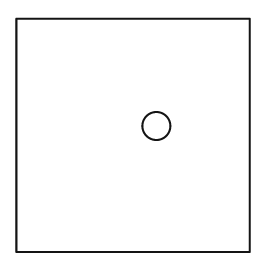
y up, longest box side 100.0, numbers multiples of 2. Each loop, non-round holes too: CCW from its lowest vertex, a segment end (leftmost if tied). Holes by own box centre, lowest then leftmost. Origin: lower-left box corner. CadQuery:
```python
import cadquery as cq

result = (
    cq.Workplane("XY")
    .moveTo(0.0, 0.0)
    .lineTo(100.0, 0.0)
    .lineTo(100.0, 100.0)
    .lineTo(0.0, 100.0)
    .close()
    .moveTo(60.0, 54.0)
    .circle(6.0)
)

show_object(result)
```